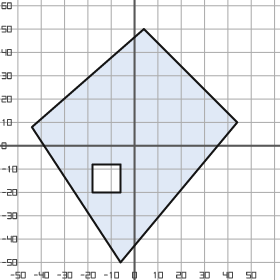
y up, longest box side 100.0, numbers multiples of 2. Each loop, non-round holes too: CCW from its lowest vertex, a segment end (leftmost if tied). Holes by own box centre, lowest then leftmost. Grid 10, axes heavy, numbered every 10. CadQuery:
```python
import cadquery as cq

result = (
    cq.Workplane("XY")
    .moveTo(-6.0, -50.0)
    .lineTo(44.0, 10.0)
    .lineTo(4.0, 50.0)
    .lineTo(-44.0, 8.0)
    .close()
    .moveTo(-18.0, -20.0)
    .lineTo(-6.0, -20.0)
    .lineTo(-6.0, -8.0)
    .lineTo(-18.0, -8.0)
    .close()
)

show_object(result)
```